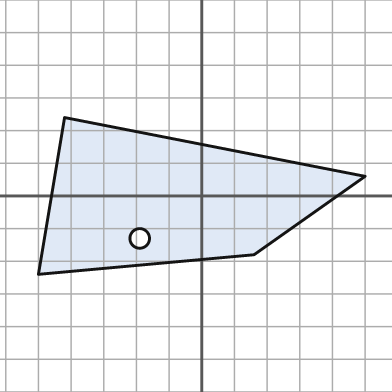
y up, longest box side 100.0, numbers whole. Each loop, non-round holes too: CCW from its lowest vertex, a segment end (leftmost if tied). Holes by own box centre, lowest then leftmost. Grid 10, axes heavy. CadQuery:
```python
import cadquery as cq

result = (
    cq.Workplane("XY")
    .moveTo(-50.0, -24.0)
    .lineTo(16.0, -18.0)
    .lineTo(50.0, 6.0)
    .lineTo(-42.0, 24.0)
    .close()
    .moveTo(-19.0, -13.0)
    .circle(3.0)
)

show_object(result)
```